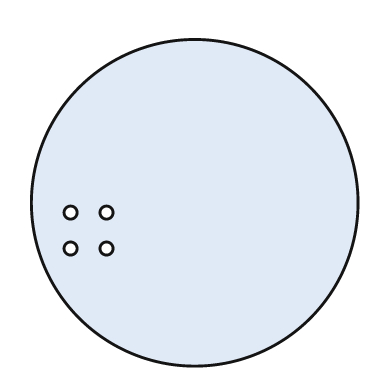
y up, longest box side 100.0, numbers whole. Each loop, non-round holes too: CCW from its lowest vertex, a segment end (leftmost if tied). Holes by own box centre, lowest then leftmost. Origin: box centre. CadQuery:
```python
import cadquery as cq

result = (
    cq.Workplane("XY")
    .moveTo(0.0, 0.0)
    .circle(50.0)
    .moveTo(-38.0, -14.0)
    .circle(2.0)
    .moveTo(-27.0, -14.0)
    .circle(2.0)
    .moveTo(-38.0, -3.0)
    .circle(2.0)
    .moveTo(-27.0, -3.0)
    .circle(2.0)
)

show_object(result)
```